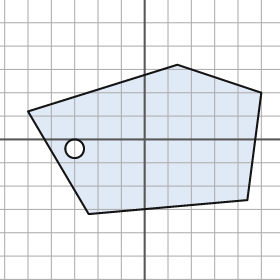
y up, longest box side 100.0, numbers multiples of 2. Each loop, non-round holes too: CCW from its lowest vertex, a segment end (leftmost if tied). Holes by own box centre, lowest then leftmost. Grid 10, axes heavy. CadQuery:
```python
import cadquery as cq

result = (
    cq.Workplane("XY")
    .moveTo(-24.0, -32.0)
    .lineTo(44.0, -26.0)
    .lineTo(50.0, 20.0)
    .lineTo(14.0, 32.0)
    .lineTo(-50.0, 12.0)
    .close()
    .moveTo(-30.0, -4.0)
    .circle(4.0)
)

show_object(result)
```